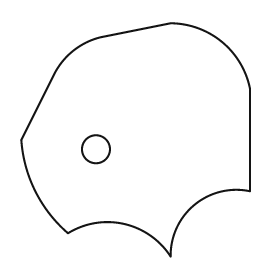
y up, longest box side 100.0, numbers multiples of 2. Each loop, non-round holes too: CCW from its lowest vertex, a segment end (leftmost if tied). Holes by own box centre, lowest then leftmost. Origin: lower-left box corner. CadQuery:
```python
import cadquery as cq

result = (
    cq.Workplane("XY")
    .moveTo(64.0, 0.0)
    .threePointArc((74.0, 22.0), (98.0, 28.0))
    .lineTo(98.0, 72.0)
    .threePointArc((86.0, 92.0), (64.0, 100.0))
    .lineTo(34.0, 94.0)
    .threePointArc((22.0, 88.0), (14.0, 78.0))
    .lineTo(0.0, 50.0)
    .threePointArc((6.0, 28.0), (20.0, 10.0))
    .threePointArc((44.0, 14.0), (64.0, 0.0))
    .close()
    .moveTo(32.0, 46.0)
    .circle(6.0)
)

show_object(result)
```